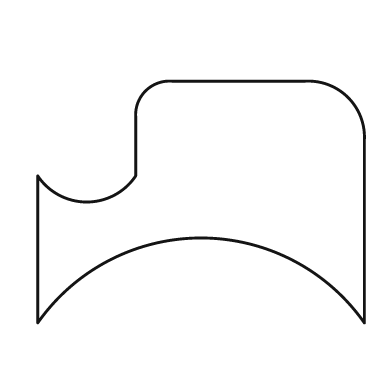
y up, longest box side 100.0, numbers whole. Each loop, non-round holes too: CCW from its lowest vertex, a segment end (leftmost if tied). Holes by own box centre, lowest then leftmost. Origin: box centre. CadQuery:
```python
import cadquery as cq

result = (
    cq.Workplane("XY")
    .moveTo(-50.0, -37.0)
    .threePointArc((0.0, -11.0), (50.0, -37.0))
    .lineTo(50.0, 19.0)
    .threePointArc((45.0, 32.0), (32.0, 37.0))
    .lineTo(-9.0, 37.0)
    .threePointArc((-17.0, 34.0), (-20.0, 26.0))
    .lineTo(-20.0, 8.0)
    .threePointArc((-35.0, 0.0), (-50.0, 8.0))
    .close()
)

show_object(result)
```